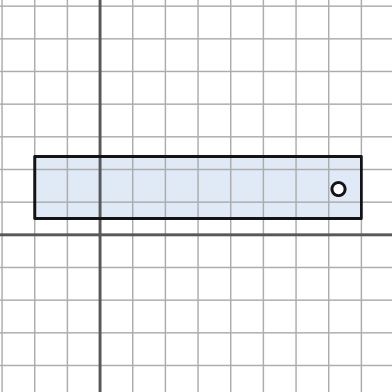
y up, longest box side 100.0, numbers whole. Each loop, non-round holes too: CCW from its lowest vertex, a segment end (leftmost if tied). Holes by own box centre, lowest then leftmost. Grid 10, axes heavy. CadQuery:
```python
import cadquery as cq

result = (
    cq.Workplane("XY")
    .moveTo(-20.0, 5.0)
    .lineTo(80.0, 5.0)
    .lineTo(80.0, 24.0)
    .lineTo(-20.0, 24.0)
    .close()
    .moveTo(73.0, 14.0)
    .circle(2.0)
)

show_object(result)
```